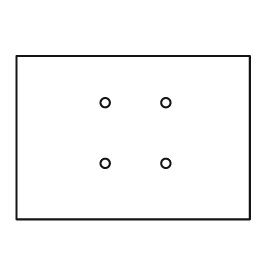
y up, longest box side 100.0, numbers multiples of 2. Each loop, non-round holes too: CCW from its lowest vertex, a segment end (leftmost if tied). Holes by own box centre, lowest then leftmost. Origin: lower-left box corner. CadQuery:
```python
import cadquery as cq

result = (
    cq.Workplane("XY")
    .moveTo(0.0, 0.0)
    .lineTo(100.0, 0.0)
    .lineTo(100.0, 70.0)
    .lineTo(0.0, 70.0)
    .close()
    .moveTo(38.0, 24.0)
    .circle(2.0)
    .moveTo(64.0, 24.0)
    .circle(2.0)
    .moveTo(38.0, 50.0)
    .circle(2.0)
    .moveTo(64.0, 50.0)
    .circle(2.0)
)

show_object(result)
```